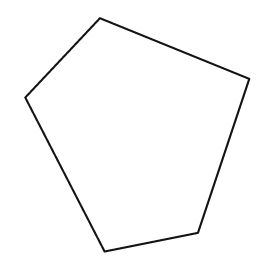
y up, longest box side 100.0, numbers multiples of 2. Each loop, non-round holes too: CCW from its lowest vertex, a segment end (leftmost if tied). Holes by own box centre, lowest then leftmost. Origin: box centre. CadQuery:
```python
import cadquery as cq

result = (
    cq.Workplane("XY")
    .moveTo(-14.0, -50.0)
    .lineTo(26.0, -42.0)
    .lineTo(48.0, 24.0)
    .lineTo(-16.0, 50.0)
    .lineTo(-48.0, 16.0)
    .close()
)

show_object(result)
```